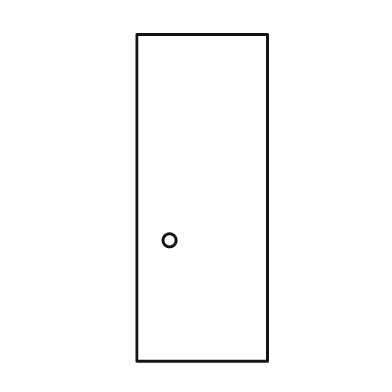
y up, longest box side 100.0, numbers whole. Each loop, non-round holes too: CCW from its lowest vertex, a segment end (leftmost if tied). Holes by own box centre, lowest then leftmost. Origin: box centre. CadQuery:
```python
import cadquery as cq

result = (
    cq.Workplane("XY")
    .moveTo(-20.0, -50.0)
    .lineTo(20.0, -50.0)
    .lineTo(20.0, 50.0)
    .lineTo(-20.0, 50.0)
    .close()
    .moveTo(-10.0, -13.0)
    .circle(2.0)
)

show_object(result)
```